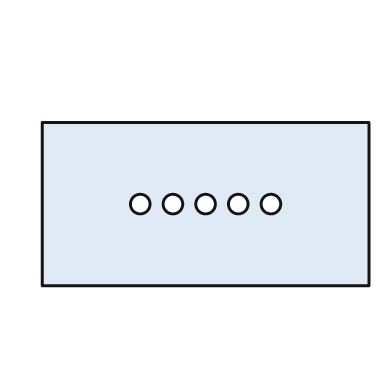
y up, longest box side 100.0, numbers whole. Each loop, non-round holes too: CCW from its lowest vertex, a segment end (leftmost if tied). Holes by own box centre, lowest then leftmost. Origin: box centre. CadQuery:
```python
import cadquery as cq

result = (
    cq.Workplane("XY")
    .moveTo(-50.0, -25.0)
    .lineTo(50.0, -25.0)
    .lineTo(50.0, 25.0)
    .lineTo(-50.0, 25.0)
    .close()
    .moveTo(-20.0, 0.0)
    .circle(3.0)
    .moveTo(-10.0, 0.0)
    .circle(3.0)
    .moveTo(0.0, 0.0)
    .circle(3.0)
    .moveTo(10.0, 0.0)
    .circle(3.0)
    .moveTo(20.0, 0.0)
    .circle(3.0)
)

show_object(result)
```